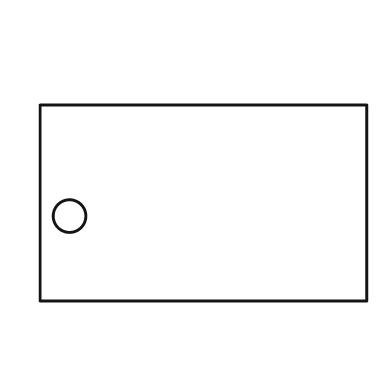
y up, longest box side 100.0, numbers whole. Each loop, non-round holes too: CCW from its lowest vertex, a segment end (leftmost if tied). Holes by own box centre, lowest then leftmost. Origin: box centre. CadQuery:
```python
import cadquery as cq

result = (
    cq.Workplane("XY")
    .moveTo(-50.0, -30.0)
    .lineTo(50.0, -30.0)
    .lineTo(50.0, 30.0)
    .lineTo(-50.0, 30.0)
    .close()
    .moveTo(-41.0, -4.0)
    .circle(5.0)
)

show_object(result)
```